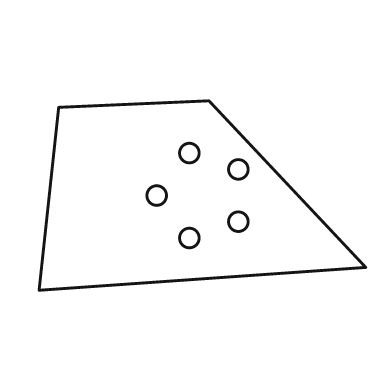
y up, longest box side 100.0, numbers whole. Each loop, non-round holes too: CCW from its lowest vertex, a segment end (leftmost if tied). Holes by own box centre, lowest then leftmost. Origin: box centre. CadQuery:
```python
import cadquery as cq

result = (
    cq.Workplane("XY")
    .moveTo(-50.0, -29.0)
    .lineTo(50.0, -22.0)
    .lineTo(2.0, 29.0)
    .lineTo(-44.0, 27.0)
    .close()
    .moveTo(-4.0, -13.0)
    .circle(3.0)
    .moveTo(11.0, -8.0)
    .circle(3.0)
    .moveTo(-14.0, 0.0)
    .circle(3.0)
    .moveTo(11.0, 8.0)
    .circle(3.0)
    .moveTo(-4.0, 13.0)
    .circle(3.0)
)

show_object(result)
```